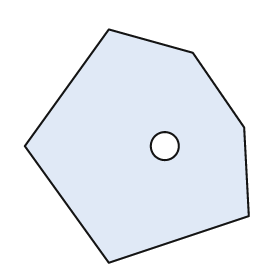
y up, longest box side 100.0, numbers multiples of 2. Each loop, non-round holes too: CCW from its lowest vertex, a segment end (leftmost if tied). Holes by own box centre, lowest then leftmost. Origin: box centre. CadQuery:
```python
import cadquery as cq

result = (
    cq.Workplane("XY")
    .moveTo(-12.0, -50.0)
    .lineTo(48.0, -30.0)
    .lineTo(46.0, 8.0)
    .lineTo(24.0, 40.0)
    .lineTo(-12.0, 50.0)
    .lineTo(-48.0, 0.0)
    .close()
    .moveTo(12.0, 0.0)
    .circle(6.0)
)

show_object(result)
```